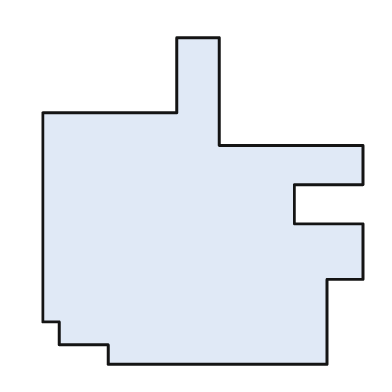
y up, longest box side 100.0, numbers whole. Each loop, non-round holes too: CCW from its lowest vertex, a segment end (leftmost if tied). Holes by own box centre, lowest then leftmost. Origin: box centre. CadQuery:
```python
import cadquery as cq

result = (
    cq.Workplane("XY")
    .moveTo(-29.0, -50.0)
    .lineTo(38.0, -50.0)
    .lineTo(38.0, -24.0)
    .lineTo(49.0, -24.0)
    .lineTo(49.0, -7.0)
    .lineTo(28.0, -7.0)
    .lineTo(28.0, 5.0)
    .lineTo(49.0, 5.0)
    .lineTo(49.0, 17.0)
    .lineTo(5.0, 17.0)
    .lineTo(5.0, 50.0)
    .lineTo(-8.0, 50.0)
    .lineTo(-8.0, 27.0)
    .lineTo(-49.0, 27.0)
    .lineTo(-49.0, -37.0)
    .lineTo(-44.0, -37.0)
    .lineTo(-44.0, -44.0)
    .lineTo(-29.0, -44.0)
    .close()
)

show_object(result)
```